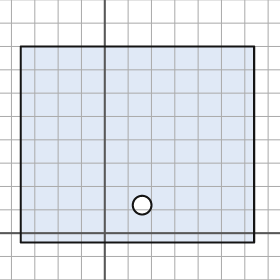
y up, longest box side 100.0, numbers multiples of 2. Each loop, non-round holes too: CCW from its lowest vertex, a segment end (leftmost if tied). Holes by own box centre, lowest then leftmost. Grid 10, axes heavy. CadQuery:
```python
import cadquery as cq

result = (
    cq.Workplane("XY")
    .moveTo(-36.0, -4.0)
    .lineTo(64.0, -4.0)
    .lineTo(64.0, 80.0)
    .lineTo(-36.0, 80.0)
    .close()
    .moveTo(16.0, 12.0)
    .circle(4.0)
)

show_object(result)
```